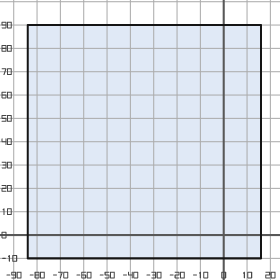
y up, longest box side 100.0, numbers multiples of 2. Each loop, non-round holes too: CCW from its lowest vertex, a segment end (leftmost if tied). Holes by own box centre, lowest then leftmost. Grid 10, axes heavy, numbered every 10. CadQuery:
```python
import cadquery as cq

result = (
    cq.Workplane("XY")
    .moveTo(-84.0, -10.0)
    .lineTo(16.0, -10.0)
    .lineTo(16.0, 90.0)
    .lineTo(-84.0, 90.0)
    .close()
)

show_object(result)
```